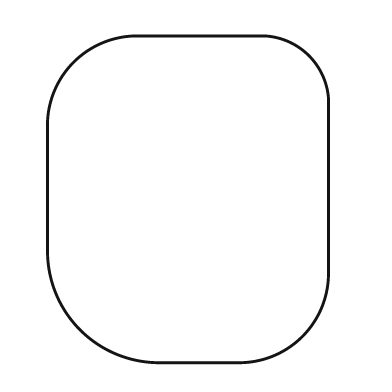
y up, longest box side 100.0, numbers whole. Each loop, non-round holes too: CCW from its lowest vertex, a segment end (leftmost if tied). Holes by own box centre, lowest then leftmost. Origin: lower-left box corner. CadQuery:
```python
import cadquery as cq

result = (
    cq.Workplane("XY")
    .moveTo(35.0, 0.0)
    .lineTo(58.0, 0.0)
    .threePointArc((78.0, 8.0), (86.0, 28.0))
    .lineTo(86.0, 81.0)
    .threePointArc((80.0, 94.0), (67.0, 100.0))
    .lineTo(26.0, 100.0)
    .threePointArc((8.0, 92.0), (0.0, 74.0))
    .lineTo(0.0, 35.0)
    .threePointArc((10.0, 10.0), (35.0, 0.0))
    .close()
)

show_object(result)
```